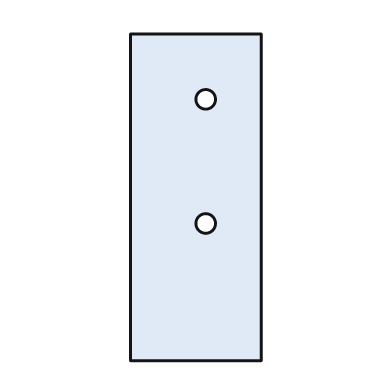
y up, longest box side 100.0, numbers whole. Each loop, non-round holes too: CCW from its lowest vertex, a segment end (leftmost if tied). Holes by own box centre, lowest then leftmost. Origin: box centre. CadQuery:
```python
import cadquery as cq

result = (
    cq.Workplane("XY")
    .moveTo(-20.0, -50.0)
    .lineTo(20.0, -50.0)
    .lineTo(20.0, 50.0)
    .lineTo(-20.0, 50.0)
    .close()
    .moveTo(3.0, -8.0)
    .circle(3.0)
    .moveTo(3.0, 30.0)
    .circle(3.0)
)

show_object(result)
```